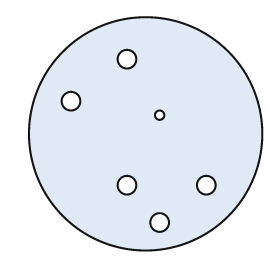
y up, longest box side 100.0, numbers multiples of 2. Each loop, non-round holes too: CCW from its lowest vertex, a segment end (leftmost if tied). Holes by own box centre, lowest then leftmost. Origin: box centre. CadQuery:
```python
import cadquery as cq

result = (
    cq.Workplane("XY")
    .moveTo(0.0, 0.0)
    .circle(50.0)
    .moveTo(6.0, -38.0)
    .circle(4.0)
    .moveTo(-8.0, -22.0)
    .circle(4.0)
    .moveTo(26.0, -22.0)
    .circle(4.0)
    .moveTo(6.0, 8.0)
    .circle(2.0)
    .moveTo(-32.0, 14.0)
    .circle(4.0)
    .moveTo(-8.0, 32.0)
    .circle(4.0)
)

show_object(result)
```